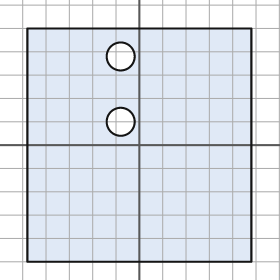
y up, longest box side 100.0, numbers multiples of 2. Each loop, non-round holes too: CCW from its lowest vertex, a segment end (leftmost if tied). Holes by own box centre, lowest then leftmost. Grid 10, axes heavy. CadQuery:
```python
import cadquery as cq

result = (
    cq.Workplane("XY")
    .moveTo(-48.0, -50.0)
    .lineTo(48.0, -50.0)
    .lineTo(48.0, 50.0)
    .lineTo(-48.0, 50.0)
    .close()
    .moveTo(-8.0, 10.0)
    .circle(6.0)
    .moveTo(-8.0, 38.0)
    .circle(6.0)
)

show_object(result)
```